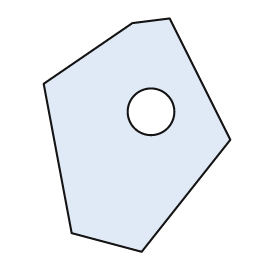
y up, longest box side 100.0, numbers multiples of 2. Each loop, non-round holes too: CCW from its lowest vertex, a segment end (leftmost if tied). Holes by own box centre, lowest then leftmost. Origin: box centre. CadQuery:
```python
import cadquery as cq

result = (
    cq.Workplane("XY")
    .moveTo(2.0, -50.0)
    .lineTo(40.0, -2.0)
    .lineTo(14.0, 50.0)
    .lineTo(-2.0, 48.0)
    .lineTo(-40.0, 22.0)
    .lineTo(-28.0, -42.0)
    .close()
    .moveTo(6.0, 10.0)
    .circle(10.0)
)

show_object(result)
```